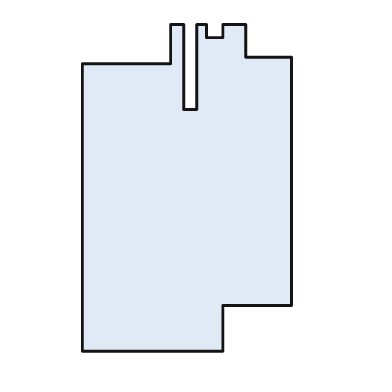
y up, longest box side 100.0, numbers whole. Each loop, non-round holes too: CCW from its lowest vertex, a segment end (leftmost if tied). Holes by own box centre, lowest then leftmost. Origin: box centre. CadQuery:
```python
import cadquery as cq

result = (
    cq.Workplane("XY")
    .moveTo(-32.0, -50.0)
    .lineTo(11.0, -50.0)
    .lineTo(11.0, -36.0)
    .lineTo(32.0, -36.0)
    .lineTo(32.0, 40.0)
    .lineTo(18.0, 40.0)
    .lineTo(18.0, 50.0)
    .lineTo(11.0, 50.0)
    .lineTo(11.0, 46.0)
    .lineTo(6.0, 46.0)
    .lineTo(6.0, 50.0)
    .lineTo(3.0, 50.0)
    .lineTo(3.0, 24.0)
    .lineTo(-1.0, 24.0)
    .lineTo(-1.0, 50.0)
    .lineTo(-5.0, 50.0)
    .lineTo(-5.0, 38.0)
    .lineTo(-32.0, 38.0)
    .close()
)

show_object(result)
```